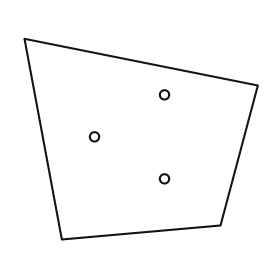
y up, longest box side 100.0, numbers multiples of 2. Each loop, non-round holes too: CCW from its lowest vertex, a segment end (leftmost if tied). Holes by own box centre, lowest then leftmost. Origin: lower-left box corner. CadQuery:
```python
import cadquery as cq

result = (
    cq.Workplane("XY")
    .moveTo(16.0, 0.0)
    .lineTo(84.0, 6.0)
    .lineTo(100.0, 66.0)
    .lineTo(0.0, 86.0)
    .close()
    .moveTo(60.0, 26.0)
    .circle(2.0)
    .moveTo(30.0, 44.0)
    .circle(2.0)
    .moveTo(60.0, 62.0)
    .circle(2.0)
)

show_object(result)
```